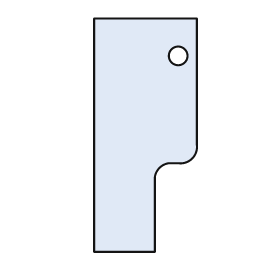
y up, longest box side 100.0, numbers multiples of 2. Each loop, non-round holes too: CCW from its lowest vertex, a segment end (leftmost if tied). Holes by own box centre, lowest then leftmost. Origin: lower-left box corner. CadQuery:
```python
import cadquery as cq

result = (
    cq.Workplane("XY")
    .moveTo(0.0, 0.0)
    .lineTo(26.0, 0.0)
    .lineTo(26.0, 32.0)
    .threePointArc((28.0, 36.0), (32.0, 38.0))
    .lineTo(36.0, 38.0)
    .threePointArc((42.0, 40.0), (44.0, 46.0))
    .lineTo(44.0, 100.0)
    .lineTo(0.0, 100.0)
    .close()
    .moveTo(36.0, 84.0)
    .circle(4.0)
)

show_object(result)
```